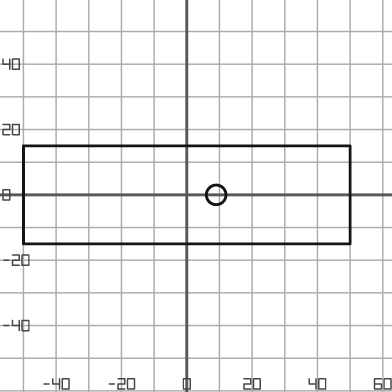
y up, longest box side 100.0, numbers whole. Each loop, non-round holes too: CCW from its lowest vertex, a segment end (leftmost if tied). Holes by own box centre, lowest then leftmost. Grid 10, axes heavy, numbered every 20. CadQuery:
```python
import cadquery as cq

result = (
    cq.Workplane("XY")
    .moveTo(-50.0, -15.0)
    .lineTo(50.0, -15.0)
    .lineTo(50.0, 15.0)
    .lineTo(-50.0, 15.0)
    .close()
    .moveTo(9.0, 0.0)
    .circle(3.0)
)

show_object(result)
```